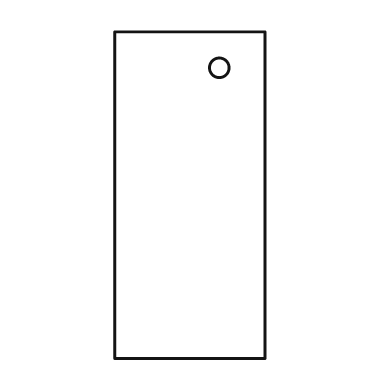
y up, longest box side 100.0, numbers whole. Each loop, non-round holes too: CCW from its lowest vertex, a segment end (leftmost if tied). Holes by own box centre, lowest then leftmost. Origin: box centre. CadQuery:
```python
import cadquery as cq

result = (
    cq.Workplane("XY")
    .moveTo(-23.0, -50.0)
    .lineTo(23.0, -50.0)
    .lineTo(23.0, 50.0)
    .lineTo(-23.0, 50.0)
    .close()
    .moveTo(9.0, 39.0)
    .circle(3.0)
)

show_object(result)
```